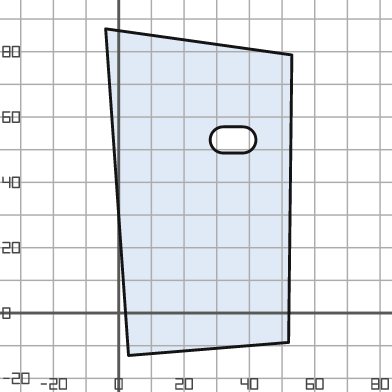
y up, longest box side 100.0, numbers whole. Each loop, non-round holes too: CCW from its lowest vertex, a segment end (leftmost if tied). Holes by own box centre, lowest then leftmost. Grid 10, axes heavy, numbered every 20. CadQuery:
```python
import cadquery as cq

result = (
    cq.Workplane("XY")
    .moveTo(3.0, -13.0)
    .lineTo(52.0, -9.0)
    .lineTo(53.0, 79.0)
    .lineTo(-4.0, 87.0)
    .close()
    .moveTo(32.0, 49.0)
    .lineTo(38.0, 49.0)
    .threePointArc((42.0, 53.0), (38.0, 57.0))
    .lineTo(32.0, 57.0)
    .threePointArc((28.0, 53.0), (32.0, 49.0))
    .close()
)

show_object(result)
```